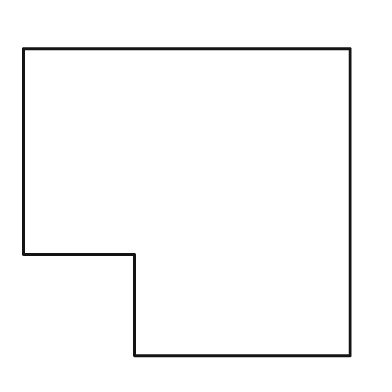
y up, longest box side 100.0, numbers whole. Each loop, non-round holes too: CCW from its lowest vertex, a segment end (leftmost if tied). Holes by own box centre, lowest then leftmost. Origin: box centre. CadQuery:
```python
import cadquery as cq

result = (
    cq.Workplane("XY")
    .moveTo(-16.0, -47.0)
    .lineTo(50.0, -47.0)
    .lineTo(50.0, 47.0)
    .lineTo(-50.0, 47.0)
    .lineTo(-50.0, -16.0)
    .lineTo(-16.0, -16.0)
    .close()
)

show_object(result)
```